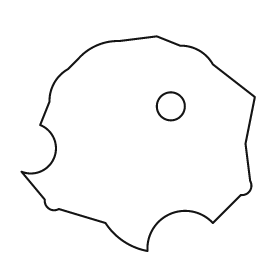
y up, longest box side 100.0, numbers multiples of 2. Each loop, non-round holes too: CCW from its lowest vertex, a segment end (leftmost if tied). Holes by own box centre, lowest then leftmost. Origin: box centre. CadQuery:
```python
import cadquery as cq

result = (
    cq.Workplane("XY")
    .moveTo(4.0, -46.0)
    .threePointArc((14.0, -30.0), (32.0, -34.0))
    .lineTo(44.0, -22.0)
    .threePointArc((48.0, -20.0), (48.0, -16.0))
    .lineTo(46.0, 0.0)
    .lineTo(50.0, 20.0)
    .lineTo(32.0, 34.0)
    .threePointArc((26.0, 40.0), (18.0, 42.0))
    .lineTo(8.0, 46.0)
    .lineTo(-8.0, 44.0)
    .threePointArc((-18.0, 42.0), (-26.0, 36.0))
    .lineTo(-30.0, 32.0)
    .threePointArc((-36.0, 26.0), (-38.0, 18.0))
    .lineTo(-42.0, 8.0)
    .threePointArc((-36.0, -6.0), (-50.0, -12.0))
    .lineTo(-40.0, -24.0)
    .threePointArc((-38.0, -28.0), (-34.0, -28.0))
    .lineTo(-14.0, -34.0)
    .threePointArc((-6.0, -42.0), (4.0, -46.0))
    .close()
    .moveTo(14.0, 16.0)
    .circle(6.0)
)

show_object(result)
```